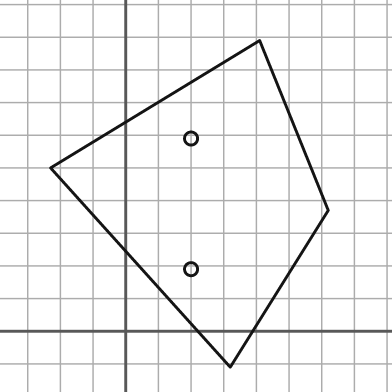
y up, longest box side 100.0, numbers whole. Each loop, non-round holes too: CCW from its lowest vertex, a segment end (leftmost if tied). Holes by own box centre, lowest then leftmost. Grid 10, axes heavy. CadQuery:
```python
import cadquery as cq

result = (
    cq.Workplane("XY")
    .moveTo(32.0, -11.0)
    .lineTo(62.0, 37.0)
    .lineTo(41.0, 89.0)
    .lineTo(-23.0, 50.0)
    .close()
    .moveTo(20.0, 19.0)
    .circle(2.0)
    .moveTo(20.0, 59.0)
    .circle(2.0)
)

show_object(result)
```